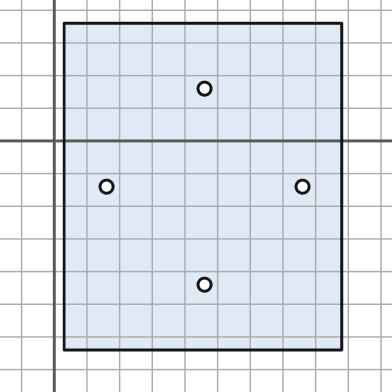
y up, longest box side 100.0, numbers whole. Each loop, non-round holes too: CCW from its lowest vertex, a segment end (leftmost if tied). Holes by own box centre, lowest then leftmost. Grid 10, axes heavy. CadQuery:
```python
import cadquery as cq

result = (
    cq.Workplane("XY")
    .moveTo(3.0, -64.0)
    .lineTo(88.0, -64.0)
    .lineTo(88.0, 36.0)
    .lineTo(3.0, 36.0)
    .close()
    .moveTo(46.0, -44.0)
    .circle(2.0)
    .moveTo(16.0, -14.0)
    .circle(2.0)
    .moveTo(76.0, -14.0)
    .circle(2.0)
    .moveTo(46.0, 16.0)
    .circle(2.0)
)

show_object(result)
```